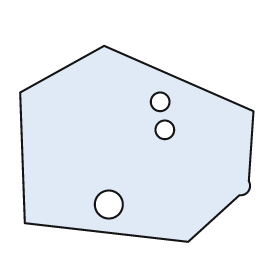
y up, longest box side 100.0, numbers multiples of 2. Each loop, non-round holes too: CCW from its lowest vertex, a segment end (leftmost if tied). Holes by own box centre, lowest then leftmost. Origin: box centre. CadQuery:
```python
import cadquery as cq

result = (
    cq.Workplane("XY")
    .moveTo(22.0, -42.0)
    .lineTo(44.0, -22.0)
    .threePointArc((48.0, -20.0), (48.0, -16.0))
    .lineTo(50.0, 14.0)
    .lineTo(-14.0, 42.0)
    .lineTo(-50.0, 22.0)
    .lineTo(-48.0, -34.0)
    .close()
    .moveTo(-12.0, -26.0)
    .circle(6.0)
    .moveTo(12.0, 6.0)
    .circle(4.0)
    .moveTo(10.0, 18.0)
    .circle(4.0)
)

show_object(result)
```